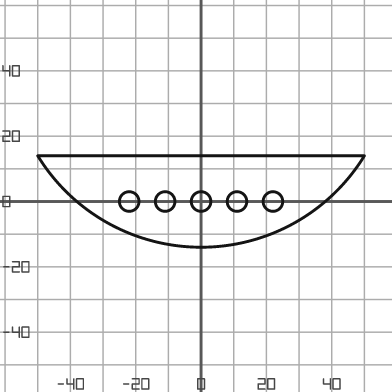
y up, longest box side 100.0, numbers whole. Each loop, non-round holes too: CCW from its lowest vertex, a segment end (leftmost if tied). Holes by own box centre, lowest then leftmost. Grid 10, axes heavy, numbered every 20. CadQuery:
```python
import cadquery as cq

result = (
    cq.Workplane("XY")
    .moveTo(-50.0, 14.0)
    .threePointArc((0.0, -14.0), (50.0, 14.0))
    .close()
    .moveTo(-22.0, 0.0)
    .circle(3.0)
    .moveTo(-11.0, 0.0)
    .circle(3.0)
    .moveTo(0.0, 0.0)
    .circle(3.0)
    .moveTo(11.0, 0.0)
    .circle(3.0)
    .moveTo(22.0, 0.0)
    .circle(3.0)
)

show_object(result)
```